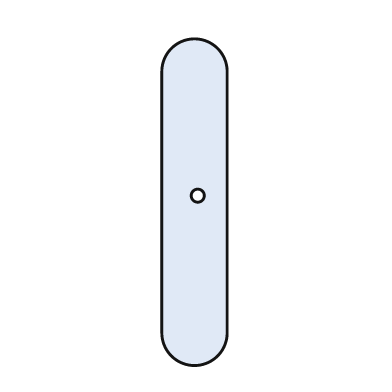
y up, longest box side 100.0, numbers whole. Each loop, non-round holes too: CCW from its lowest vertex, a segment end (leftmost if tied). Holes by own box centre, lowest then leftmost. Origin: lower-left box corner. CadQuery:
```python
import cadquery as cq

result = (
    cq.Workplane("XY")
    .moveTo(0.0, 10.0)
    .threePointArc((10.0, 0.0), (20.0, 10.0))
    .lineTo(20.0, 90.0)
    .threePointArc((10.0, 100.0), (0.0, 90.0))
    .close()
    .moveTo(11.0, 52.0)
    .circle(2.0)
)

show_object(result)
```